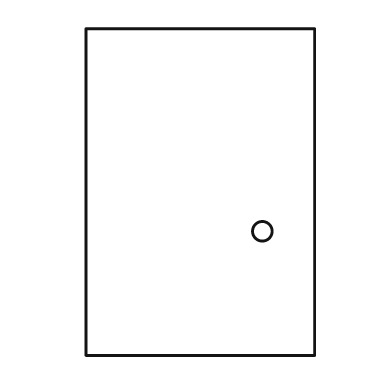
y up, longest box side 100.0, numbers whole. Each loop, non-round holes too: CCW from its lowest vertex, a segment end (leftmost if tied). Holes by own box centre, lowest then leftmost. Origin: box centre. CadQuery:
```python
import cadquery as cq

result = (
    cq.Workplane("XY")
    .moveTo(-35.0, -50.0)
    .lineTo(35.0, -50.0)
    .lineTo(35.0, 50.0)
    .lineTo(-35.0, 50.0)
    .close()
    .moveTo(19.0, -12.0)
    .circle(3.0)
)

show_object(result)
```